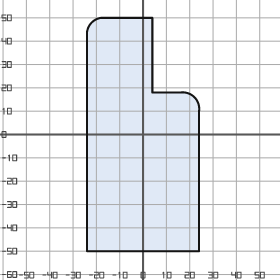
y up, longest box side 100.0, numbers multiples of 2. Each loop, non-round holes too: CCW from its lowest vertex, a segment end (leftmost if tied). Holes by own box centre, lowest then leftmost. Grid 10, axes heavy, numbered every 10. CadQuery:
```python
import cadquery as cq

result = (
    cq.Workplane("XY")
    .moveTo(-24.0, -50.0)
    .lineTo(24.0, -50.0)
    .lineTo(24.0, 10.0)
    .threePointArc((22.0, 16.0), (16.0, 18.0))
    .lineTo(4.0, 18.0)
    .lineTo(4.0, 50.0)
    .lineTo(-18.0, 50.0)
    .threePointArc((-22.0, 48.0), (-24.0, 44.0))
    .close()
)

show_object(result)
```